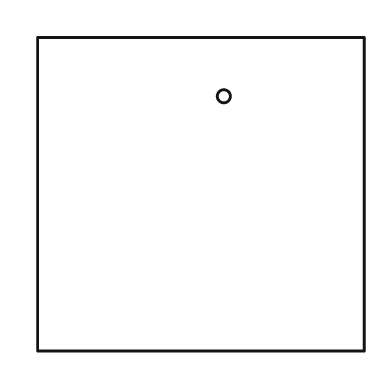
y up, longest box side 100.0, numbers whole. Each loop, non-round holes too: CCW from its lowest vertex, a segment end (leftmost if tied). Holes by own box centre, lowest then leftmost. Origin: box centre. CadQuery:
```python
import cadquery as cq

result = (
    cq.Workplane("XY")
    .moveTo(-50.0, -48.0)
    .lineTo(50.0, -48.0)
    .lineTo(50.0, 48.0)
    .lineTo(-50.0, 48.0)
    .close()
    .moveTo(7.0, 30.0)
    .circle(2.0)
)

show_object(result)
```